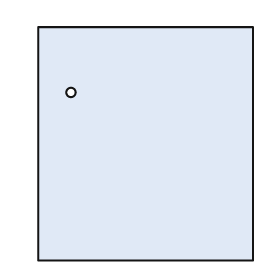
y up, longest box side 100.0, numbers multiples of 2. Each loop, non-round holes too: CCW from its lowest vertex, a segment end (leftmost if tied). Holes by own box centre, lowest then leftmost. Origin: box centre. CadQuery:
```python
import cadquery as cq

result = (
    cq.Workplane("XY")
    .moveTo(-46.0, -50.0)
    .lineTo(46.0, -50.0)
    .lineTo(46.0, 50.0)
    .lineTo(-46.0, 50.0)
    .close()
    .moveTo(-32.0, 22.0)
    .circle(2.0)
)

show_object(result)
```